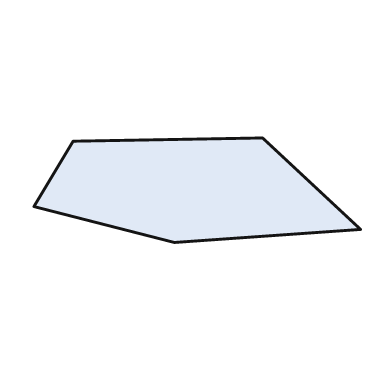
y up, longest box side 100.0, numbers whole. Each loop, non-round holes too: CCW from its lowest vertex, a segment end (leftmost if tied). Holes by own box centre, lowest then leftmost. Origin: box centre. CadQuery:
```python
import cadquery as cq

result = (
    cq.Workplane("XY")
    .moveTo(-7.0, -16.0)
    .lineTo(50.0, -12.0)
    .lineTo(20.0, 16.0)
    .lineTo(-38.0, 15.0)
    .lineTo(-50.0, -5.0)
    .close()
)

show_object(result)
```